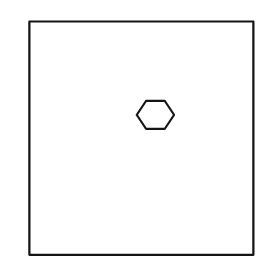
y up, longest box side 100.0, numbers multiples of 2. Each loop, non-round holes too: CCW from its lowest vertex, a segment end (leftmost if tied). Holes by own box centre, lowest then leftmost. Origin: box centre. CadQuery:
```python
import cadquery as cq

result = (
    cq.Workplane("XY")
    .moveTo(-48.0, -50.0)
    .lineTo(48.0, -50.0)
    .lineTo(48.0, 50.0)
    .lineTo(-48.0, 50.0)
    .close()
    .moveTo(2.0, 4.0)
    .lineTo(10.0, 4.0)
    .lineTo(14.0, 10.0)
    .lineTo(10.0, 16.0)
    .lineTo(2.0, 16.0)
    .lineTo(-2.0, 10.0)
    .close()
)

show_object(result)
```